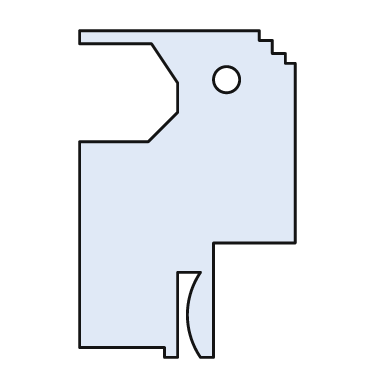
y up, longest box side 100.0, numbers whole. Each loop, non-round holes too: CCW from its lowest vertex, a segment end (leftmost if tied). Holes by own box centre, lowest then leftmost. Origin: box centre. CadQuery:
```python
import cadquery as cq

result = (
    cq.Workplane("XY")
    .moveTo(-7.0, -50.0)
    .lineTo(-3.0, -50.0)
    .lineTo(-3.0, -24.0)
    .lineTo(4.0, -24.0)
    .threePointArc((0.0, -37.0), (4.0, -50.0))
    .lineTo(8.0, -50.0)
    .lineTo(8.0, -15.0)
    .lineTo(33.0, -15.0)
    .lineTo(33.0, 40.0)
    .lineTo(30.0, 40.0)
    .lineTo(30.0, 43.0)
    .lineTo(26.0, 43.0)
    .lineTo(26.0, 47.0)
    .lineTo(22.0, 47.0)
    .lineTo(22.0, 50.0)
    .lineTo(-33.0, 50.0)
    .lineTo(-33.0, 46.0)
    .lineTo(-11.0, 46.0)
    .lineTo(-3.0, 34.0)
    .lineTo(-3.0, 25.0)
    .lineTo(-12.0, 16.0)
    .lineTo(-33.0, 16.0)
    .lineTo(-33.0, -47.0)
    .lineTo(-7.0, -47.0)
    .close()
    .moveTo(12.0, 35.0)
    .circle(4.0)
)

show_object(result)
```